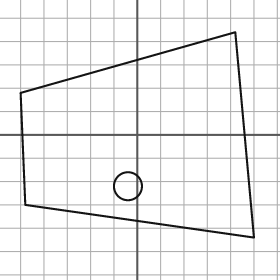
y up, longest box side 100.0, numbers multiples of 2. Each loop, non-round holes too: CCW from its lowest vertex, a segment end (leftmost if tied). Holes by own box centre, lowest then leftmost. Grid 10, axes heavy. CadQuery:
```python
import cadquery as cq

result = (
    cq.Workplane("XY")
    .moveTo(50.0, -44.0)
    .lineTo(42.0, 44.0)
    .lineTo(-50.0, 18.0)
    .lineTo(-48.0, -30.0)
    .close()
    .moveTo(-4.0, -22.0)
    .circle(6.0)
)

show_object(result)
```